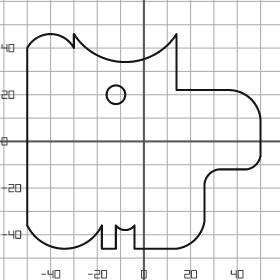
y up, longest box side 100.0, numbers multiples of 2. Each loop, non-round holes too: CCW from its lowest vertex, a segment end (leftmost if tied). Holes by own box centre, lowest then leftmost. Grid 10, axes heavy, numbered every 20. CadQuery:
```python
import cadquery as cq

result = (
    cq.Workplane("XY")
    .moveTo(-18.0, -46.0)
    .lineTo(-12.0, -46.0)
    .lineTo(-12.0, -36.0)
    .threePointArc((-8.0, -38.0), (-4.0, -36.0))
    .lineTo(-4.0, -46.0)
    .lineTo(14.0, -46.0)
    .threePointArc((22.0, -42.0), (26.0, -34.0))
    .lineTo(26.0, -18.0)
    .threePointArc((28.0, -14.0), (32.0, -12.0))
    .lineTo(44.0, -12.0)
    .threePointArc((48.0, -10.0), (50.0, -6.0))
    .lineTo(50.0, 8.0)
    .threePointArc((46.0, 18.0), (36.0, 22.0))
    .lineTo(14.0, 22.0)
    .lineTo(14.0, 46.0)
    .threePointArc((-8.0, 34.0), (-30.0, 46.0))
    .lineTo(-30.0, 40.0)
    .threePointArc((-40.0, 46.0), (-50.0, 40.0))
    .lineTo(-50.0, -36.0)
    .threePointArc((-34.0, -46.0), (-18.0, -36.0))
    .close()
    .moveTo(-12.0, 20.0)
    .circle(4.0)
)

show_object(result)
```